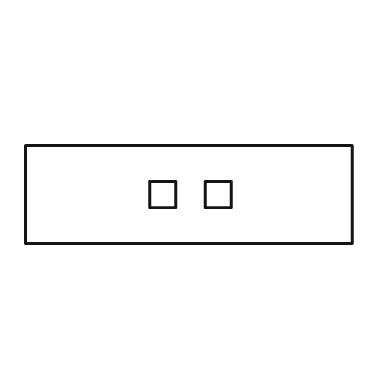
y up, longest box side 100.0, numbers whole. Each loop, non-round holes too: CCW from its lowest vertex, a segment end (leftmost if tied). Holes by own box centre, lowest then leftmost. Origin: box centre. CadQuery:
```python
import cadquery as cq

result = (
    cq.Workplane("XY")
    .moveTo(-50.0, -15.0)
    .lineTo(50.0, -15.0)
    .lineTo(50.0, 15.0)
    .lineTo(-50.0, 15.0)
    .close()
    .moveTo(-12.0, -4.0)
    .lineTo(-4.0, -4.0)
    .lineTo(-4.0, 4.0)
    .lineTo(-12.0, 4.0)
    .close()
    .moveTo(5.0, -4.0)
    .lineTo(13.0, -4.0)
    .lineTo(13.0, 4.0)
    .lineTo(5.0, 4.0)
    .close()
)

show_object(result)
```